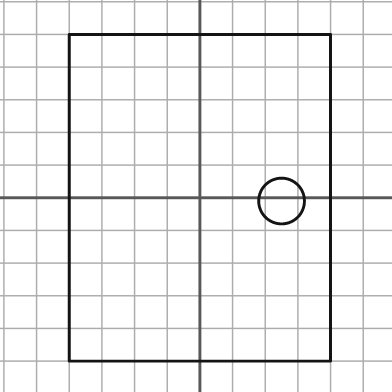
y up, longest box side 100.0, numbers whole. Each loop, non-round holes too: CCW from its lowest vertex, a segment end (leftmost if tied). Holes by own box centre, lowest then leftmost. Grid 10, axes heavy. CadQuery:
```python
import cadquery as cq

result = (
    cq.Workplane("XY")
    .moveTo(-40.0, -50.0)
    .lineTo(40.0, -50.0)
    .lineTo(40.0, 50.0)
    .lineTo(-40.0, 50.0)
    .close()
    .moveTo(25.0, -1.0)
    .circle(7.0)
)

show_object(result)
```